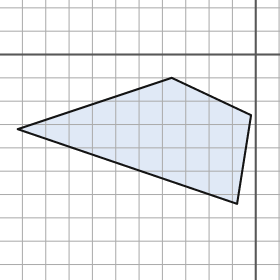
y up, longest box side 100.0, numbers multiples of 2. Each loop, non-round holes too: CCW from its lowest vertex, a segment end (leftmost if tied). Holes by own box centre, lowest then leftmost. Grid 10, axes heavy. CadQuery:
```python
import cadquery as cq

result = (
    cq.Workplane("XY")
    .moveTo(-8.0, -64.0)
    .lineTo(-2.0, -26.0)
    .lineTo(-36.0, -10.0)
    .lineTo(-102.0, -32.0)
    .close()
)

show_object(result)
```